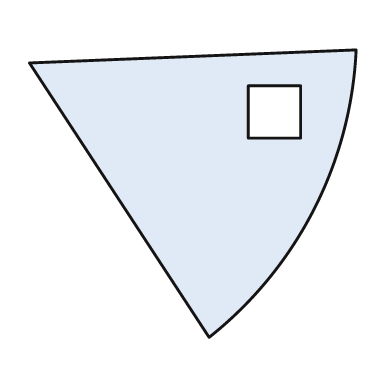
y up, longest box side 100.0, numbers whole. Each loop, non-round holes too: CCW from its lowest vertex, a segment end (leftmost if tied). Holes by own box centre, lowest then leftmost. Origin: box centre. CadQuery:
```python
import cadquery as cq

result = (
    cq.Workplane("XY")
    .moveTo(5.0, -44.0)
    .threePointArc((37.0, -5.0), (50.0, 44.0))
    .lineTo(-50.0, 40.0)
    .close()
    .moveTo(17.0, 17.0)
    .lineTo(33.0, 17.0)
    .lineTo(33.0, 33.0)
    .lineTo(17.0, 33.0)
    .close()
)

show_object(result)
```